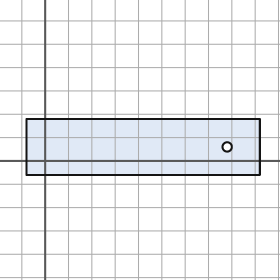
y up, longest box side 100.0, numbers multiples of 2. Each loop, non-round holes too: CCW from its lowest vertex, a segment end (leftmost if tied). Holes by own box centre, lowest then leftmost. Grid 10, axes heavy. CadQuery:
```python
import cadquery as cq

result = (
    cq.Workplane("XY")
    .moveTo(-8.0, -6.0)
    .lineTo(92.0, -6.0)
    .lineTo(92.0, 18.0)
    .lineTo(-8.0, 18.0)
    .close()
    .moveTo(78.0, 6.0)
    .circle(2.0)
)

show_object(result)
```